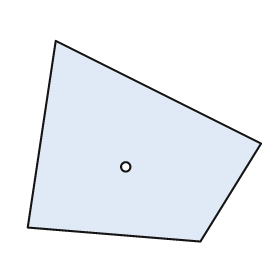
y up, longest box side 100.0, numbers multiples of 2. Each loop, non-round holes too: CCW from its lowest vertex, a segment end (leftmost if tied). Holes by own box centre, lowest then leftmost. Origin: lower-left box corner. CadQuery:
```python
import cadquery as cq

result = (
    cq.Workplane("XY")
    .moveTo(74.0, 0.0)
    .lineTo(100.0, 42.0)
    .lineTo(12.0, 86.0)
    .lineTo(0.0, 6.0)
    .close()
    .moveTo(42.0, 32.0)
    .circle(2.0)
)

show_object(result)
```